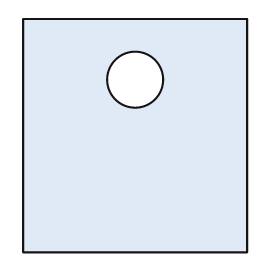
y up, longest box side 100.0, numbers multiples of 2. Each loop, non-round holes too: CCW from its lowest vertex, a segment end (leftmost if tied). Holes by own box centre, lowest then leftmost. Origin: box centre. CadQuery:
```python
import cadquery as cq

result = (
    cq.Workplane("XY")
    .moveTo(-48.0, -50.0)
    .lineTo(48.0, -50.0)
    .lineTo(48.0, 50.0)
    .lineTo(-48.0, 50.0)
    .close()
    .moveTo(0.0, 24.0)
    .circle(12.0)
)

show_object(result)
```